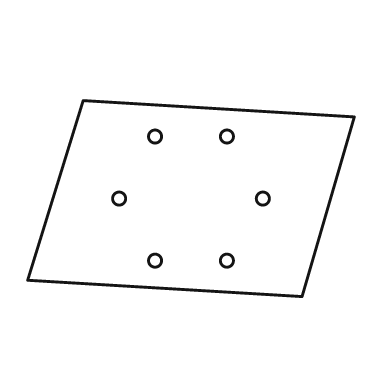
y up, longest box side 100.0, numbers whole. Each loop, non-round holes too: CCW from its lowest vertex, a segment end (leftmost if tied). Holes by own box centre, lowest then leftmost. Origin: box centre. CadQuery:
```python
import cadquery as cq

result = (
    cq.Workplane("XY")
    .moveTo(34.0, -30.0)
    .lineTo(50.0, 25.0)
    .lineTo(-33.0, 30.0)
    .lineTo(-50.0, -25.0)
    .close()
    .moveTo(-11.0, -19.0)
    .circle(2.0)
    .moveTo(11.0, -19.0)
    .circle(2.0)
    .moveTo(-22.0, 0.0)
    .circle(2.0)
    .moveTo(22.0, 0.0)
    .circle(2.0)
    .moveTo(-11.0, 19.0)
    .circle(2.0)
    .moveTo(11.0, 19.0)
    .circle(2.0)
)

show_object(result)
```